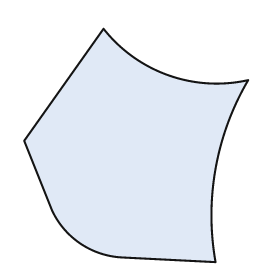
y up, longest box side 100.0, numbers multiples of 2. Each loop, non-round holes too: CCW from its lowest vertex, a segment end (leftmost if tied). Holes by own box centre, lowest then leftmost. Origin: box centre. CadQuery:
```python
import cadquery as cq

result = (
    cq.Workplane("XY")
    .moveTo(34.0, -50.0)
    .threePointArc((34.0, -10.0), (48.0, 28.0))
    .threePointArc((14.0, 30.0), (-14.0, 50.0))
    .lineTo(-48.0, 2.0)
    .lineTo(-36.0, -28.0)
    .threePointArc((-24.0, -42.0), (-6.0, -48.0))
    .close()
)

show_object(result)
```